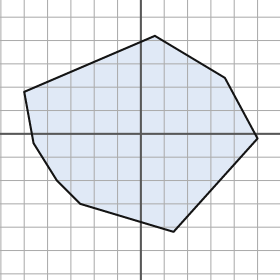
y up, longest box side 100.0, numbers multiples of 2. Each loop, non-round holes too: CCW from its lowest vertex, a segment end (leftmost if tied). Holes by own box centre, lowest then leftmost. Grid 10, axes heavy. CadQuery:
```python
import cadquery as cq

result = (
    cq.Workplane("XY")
    .moveTo(14.0, -42.0)
    .lineTo(50.0, -2.0)
    .lineTo(36.0, 24.0)
    .lineTo(6.0, 42.0)
    .lineTo(-50.0, 18.0)
    .lineTo(-46.0, -4.0)
    .lineTo(-36.0, -20.0)
    .lineTo(-26.0, -30.0)
    .close()
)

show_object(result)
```